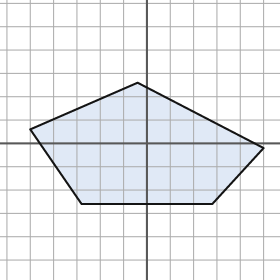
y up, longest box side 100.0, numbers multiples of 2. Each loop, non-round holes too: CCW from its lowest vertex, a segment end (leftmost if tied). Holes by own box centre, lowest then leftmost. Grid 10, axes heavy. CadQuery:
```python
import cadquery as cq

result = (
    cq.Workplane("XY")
    .moveTo(-28.0, -26.0)
    .lineTo(28.0, -26.0)
    .lineTo(50.0, -2.0)
    .lineTo(-4.0, 26.0)
    .lineTo(-50.0, 6.0)
    .close()
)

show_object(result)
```